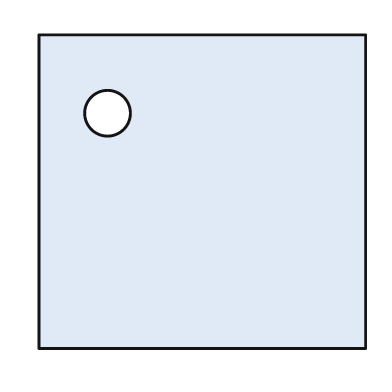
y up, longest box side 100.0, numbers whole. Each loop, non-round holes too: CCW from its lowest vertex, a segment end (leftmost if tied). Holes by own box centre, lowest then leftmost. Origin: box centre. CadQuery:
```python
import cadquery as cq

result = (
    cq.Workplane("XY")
    .moveTo(-50.0, -48.0)
    .lineTo(50.0, -48.0)
    .lineTo(50.0, 48.0)
    .lineTo(-50.0, 48.0)
    .close()
    .moveTo(-29.0, 24.0)
    .circle(7.0)
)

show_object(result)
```